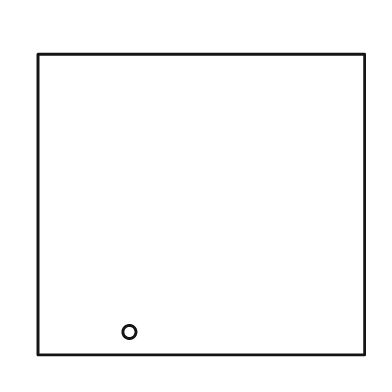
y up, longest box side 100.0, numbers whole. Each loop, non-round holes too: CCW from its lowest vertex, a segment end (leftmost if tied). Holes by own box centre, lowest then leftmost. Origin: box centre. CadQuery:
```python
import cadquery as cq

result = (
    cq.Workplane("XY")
    .moveTo(-50.0, -46.0)
    .lineTo(50.0, -46.0)
    .lineTo(50.0, 46.0)
    .lineTo(-50.0, 46.0)
    .close()
    .moveTo(-22.0, -39.0)
    .circle(2.0)
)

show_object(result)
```